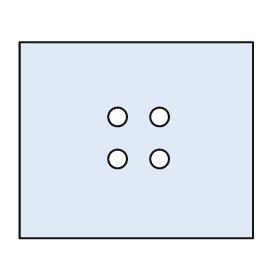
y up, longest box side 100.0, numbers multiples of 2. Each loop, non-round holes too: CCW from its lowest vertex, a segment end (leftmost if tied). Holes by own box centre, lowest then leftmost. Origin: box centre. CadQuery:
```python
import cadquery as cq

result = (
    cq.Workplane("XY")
    .moveTo(-50.0, -42.0)
    .lineTo(50.0, -42.0)
    .lineTo(50.0, 42.0)
    .lineTo(-50.0, 42.0)
    .close()
    .moveTo(-8.0, -8.0)
    .circle(4.0)
    .moveTo(10.0, -8.0)
    .circle(4.0)
    .moveTo(-8.0, 10.0)
    .circle(4.0)
    .moveTo(10.0, 10.0)
    .circle(4.0)
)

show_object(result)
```